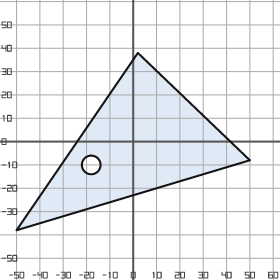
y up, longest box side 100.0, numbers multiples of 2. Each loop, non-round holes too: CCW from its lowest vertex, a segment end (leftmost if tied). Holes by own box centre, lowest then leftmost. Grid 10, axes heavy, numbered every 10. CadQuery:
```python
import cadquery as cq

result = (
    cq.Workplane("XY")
    .moveTo(-50.0, -38.0)
    .lineTo(50.0, -8.0)
    .lineTo(2.0, 38.0)
    .close()
    .moveTo(-18.0, -10.0)
    .circle(4.0)
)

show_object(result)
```